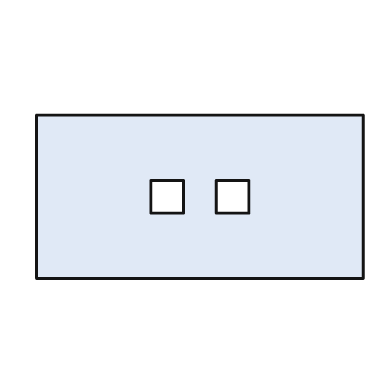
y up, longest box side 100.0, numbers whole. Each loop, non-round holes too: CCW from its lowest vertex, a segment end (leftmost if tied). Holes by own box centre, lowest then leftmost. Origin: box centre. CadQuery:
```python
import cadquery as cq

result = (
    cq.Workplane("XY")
    .moveTo(-50.0, -25.0)
    .lineTo(50.0, -25.0)
    .lineTo(50.0, 25.0)
    .lineTo(-50.0, 25.0)
    .close()
    .moveTo(-15.0, -5.0)
    .lineTo(-5.0, -5.0)
    .lineTo(-5.0, 5.0)
    .lineTo(-15.0, 5.0)
    .close()
    .moveTo(5.0, -5.0)
    .lineTo(15.0, -5.0)
    .lineTo(15.0, 5.0)
    .lineTo(5.0, 5.0)
    .close()
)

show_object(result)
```